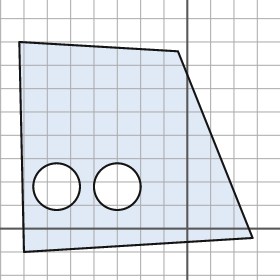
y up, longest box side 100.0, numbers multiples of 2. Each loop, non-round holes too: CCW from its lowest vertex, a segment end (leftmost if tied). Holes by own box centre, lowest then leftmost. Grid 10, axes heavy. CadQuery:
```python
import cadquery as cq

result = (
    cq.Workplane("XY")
    .moveTo(-70.0, -10.0)
    .lineTo(28.0, -4.0)
    .lineTo(-4.0, 76.0)
    .lineTo(-72.0, 80.0)
    .close()
    .moveTo(-56.0, 18.0)
    .circle(10.0)
    .moveTo(-30.0, 18.0)
    .circle(10.0)
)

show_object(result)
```